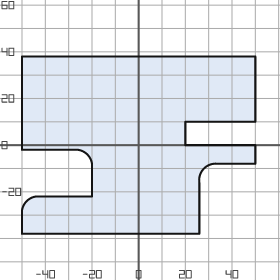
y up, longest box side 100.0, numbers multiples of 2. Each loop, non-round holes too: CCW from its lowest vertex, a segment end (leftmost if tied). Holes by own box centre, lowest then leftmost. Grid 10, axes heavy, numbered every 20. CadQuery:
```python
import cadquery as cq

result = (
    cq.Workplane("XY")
    .moveTo(-50.0, -38.0)
    .lineTo(26.0, -38.0)
    .lineTo(26.0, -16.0)
    .threePointArc((28.0, -10.0), (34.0, -8.0))
    .lineTo(50.0, -8.0)
    .lineTo(50.0, 0.0)
    .lineTo(20.0, 0.0)
    .lineTo(20.0, 10.0)
    .lineTo(50.0, 10.0)
    .lineTo(50.0, 38.0)
    .lineTo(-50.0, 38.0)
    .lineTo(-50.0, -2.0)
    .lineTo(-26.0, -2.0)
    .threePointArc((-22.0, -4.0), (-20.0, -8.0))
    .lineTo(-20.0, -22.0)
    .lineTo(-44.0, -22.0)
    .threePointArc((-48.0, -24.0), (-50.0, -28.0))
    .close()
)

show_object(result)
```